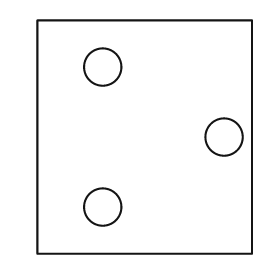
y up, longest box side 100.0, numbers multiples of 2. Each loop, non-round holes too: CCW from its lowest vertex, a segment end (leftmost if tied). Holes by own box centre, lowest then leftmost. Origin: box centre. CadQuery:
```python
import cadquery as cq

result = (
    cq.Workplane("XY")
    .moveTo(-46.0, -50.0)
    .lineTo(46.0, -50.0)
    .lineTo(46.0, 50.0)
    .lineTo(-46.0, 50.0)
    .close()
    .moveTo(-18.0, -30.0)
    .circle(8.0)
    .moveTo(34.0, 0.0)
    .circle(8.0)
    .moveTo(-18.0, 30.0)
    .circle(8.0)
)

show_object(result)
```